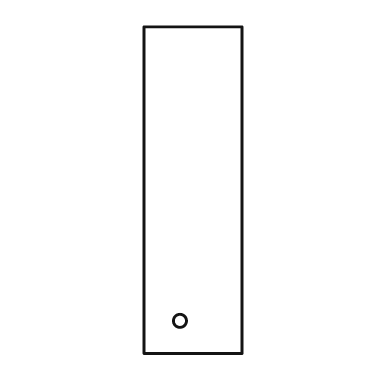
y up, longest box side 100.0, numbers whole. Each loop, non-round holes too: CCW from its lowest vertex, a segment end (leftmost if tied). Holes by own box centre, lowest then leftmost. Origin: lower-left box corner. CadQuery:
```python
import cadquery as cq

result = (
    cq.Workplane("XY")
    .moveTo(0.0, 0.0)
    .lineTo(30.0, 0.0)
    .lineTo(30.0, 100.0)
    .lineTo(0.0, 100.0)
    .close()
    .moveTo(11.0, 10.0)
    .circle(2.0)
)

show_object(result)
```